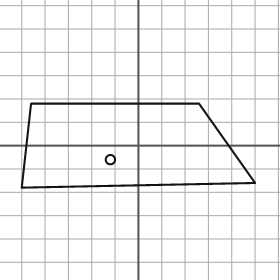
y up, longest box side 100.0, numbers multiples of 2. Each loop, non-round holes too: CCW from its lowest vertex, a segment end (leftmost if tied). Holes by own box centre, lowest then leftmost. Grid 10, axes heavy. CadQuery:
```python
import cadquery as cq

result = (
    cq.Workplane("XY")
    .moveTo(-50.0, -18.0)
    .lineTo(50.0, -16.0)
    .lineTo(26.0, 18.0)
    .lineTo(-46.0, 18.0)
    .close()
    .moveTo(-12.0, -6.0)
    .circle(2.0)
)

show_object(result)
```